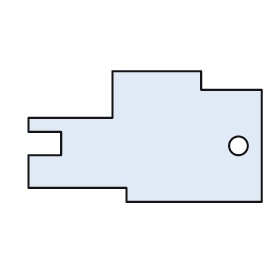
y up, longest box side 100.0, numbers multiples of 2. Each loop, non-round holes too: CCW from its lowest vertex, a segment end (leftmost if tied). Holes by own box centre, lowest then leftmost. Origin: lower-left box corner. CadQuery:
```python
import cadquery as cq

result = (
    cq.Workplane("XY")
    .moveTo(42.0, 0.0)
    .lineTo(100.0, 0.0)
    .lineTo(100.0, 48.0)
    .lineTo(74.0, 48.0)
    .lineTo(74.0, 56.0)
    .lineTo(36.0, 56.0)
    .lineTo(36.0, 36.0)
    .lineTo(0.0, 36.0)
    .lineTo(0.0, 30.0)
    .lineTo(14.0, 30.0)
    .lineTo(14.0, 20.0)
    .lineTo(0.0, 20.0)
    .lineTo(0.0, 6.0)
    .lineTo(42.0, 6.0)
    .close()
    .moveTo(90.0, 24.0)
    .circle(4.0)
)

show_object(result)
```